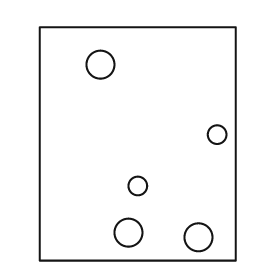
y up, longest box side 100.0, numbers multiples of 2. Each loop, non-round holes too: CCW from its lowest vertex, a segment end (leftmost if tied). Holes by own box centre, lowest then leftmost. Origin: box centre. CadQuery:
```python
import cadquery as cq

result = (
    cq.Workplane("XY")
    .moveTo(-42.0, -50.0)
    .lineTo(42.0, -50.0)
    .lineTo(42.0, 50.0)
    .lineTo(-42.0, 50.0)
    .close()
    .moveTo(26.0, -40.0)
    .circle(6.0)
    .moveTo(-4.0, -38.0)
    .circle(6.0)
    .moveTo(0.0, -18.0)
    .circle(4.0)
    .moveTo(34.0, 4.0)
    .circle(4.0)
    .moveTo(-16.0, 34.0)
    .circle(6.0)
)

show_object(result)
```